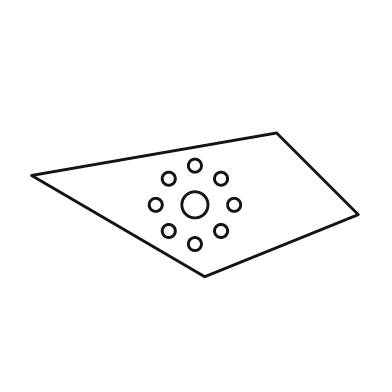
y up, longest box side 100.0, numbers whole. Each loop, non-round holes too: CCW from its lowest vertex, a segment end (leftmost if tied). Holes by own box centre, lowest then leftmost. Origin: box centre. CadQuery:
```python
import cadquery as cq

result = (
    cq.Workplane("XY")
    .moveTo(3.0, -22.0)
    .lineTo(50.0, -3.0)
    .lineTo(25.0, 22.0)
    .lineTo(-50.0, 9.0)
    .close()
    .moveTo(0.0, -12.0)
    .circle(2.0)
    .moveTo(-8.0, -8.0)
    .circle(2.0)
    .moveTo(8.0, -8.0)
    .circle(2.0)
    .moveTo(-12.0, 0.0)
    .circle(2.0)
    .moveTo(0.0, 0.0)
    .circle(4.0)
    .moveTo(12.0, 0.0)
    .circle(2.0)
    .moveTo(-8.0, 8.0)
    .circle(2.0)
    .moveTo(8.0, 8.0)
    .circle(2.0)
    .moveTo(0.0, 12.0)
    .circle(2.0)
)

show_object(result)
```